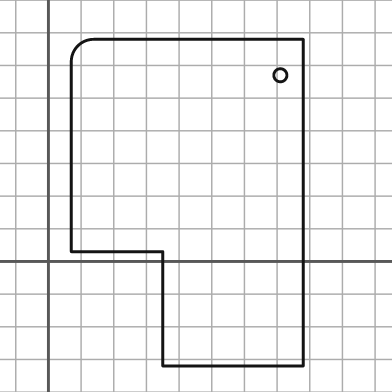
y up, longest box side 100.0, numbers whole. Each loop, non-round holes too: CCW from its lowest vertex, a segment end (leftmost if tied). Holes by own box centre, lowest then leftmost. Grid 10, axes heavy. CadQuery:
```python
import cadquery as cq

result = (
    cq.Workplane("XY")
    .moveTo(35.0, -32.0)
    .lineTo(78.0, -32.0)
    .lineTo(78.0, 68.0)
    .lineTo(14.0, 68.0)
    .threePointArc((9.0, 66.0), (7.0, 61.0))
    .lineTo(7.0, 3.0)
    .lineTo(35.0, 3.0)
    .close()
    .moveTo(71.0, 57.0)
    .circle(2.0)
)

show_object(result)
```